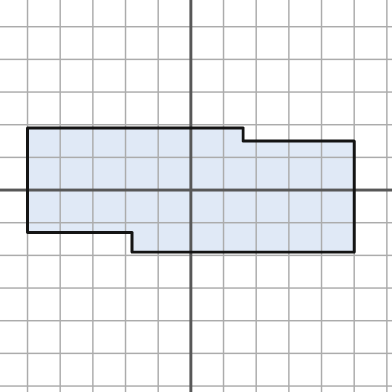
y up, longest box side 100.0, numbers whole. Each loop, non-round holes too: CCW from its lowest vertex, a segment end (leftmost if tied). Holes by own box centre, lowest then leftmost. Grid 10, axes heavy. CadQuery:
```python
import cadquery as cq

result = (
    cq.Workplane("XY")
    .moveTo(-18.0, -19.0)
    .lineTo(50.0, -19.0)
    .lineTo(50.0, 15.0)
    .lineTo(16.0, 15.0)
    .lineTo(16.0, 19.0)
    .lineTo(-50.0, 19.0)
    .lineTo(-50.0, -13.0)
    .lineTo(-18.0, -13.0)
    .close()
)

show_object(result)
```